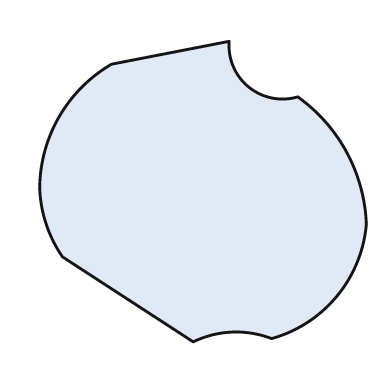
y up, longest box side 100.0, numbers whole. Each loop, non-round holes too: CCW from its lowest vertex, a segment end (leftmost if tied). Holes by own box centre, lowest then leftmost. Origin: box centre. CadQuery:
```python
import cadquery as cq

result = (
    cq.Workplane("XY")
    .moveTo(-3.0, -46.0)
    .threePointArc((9.0, -43.0), (21.0, -45.0))
    .threePointArc((41.0, -32.0), (50.0, -10.0))
    .threePointArc((44.0, 12.0), (29.0, 29.0))
    .threePointArc((14.0, 32.0), (8.0, 46.0))
    .lineTo(-28.0, 39.0)
    .threePointArc((-44.0, 23.0), (-50.0, 1.0))
    .threePointArc((-48.0, -10.0), (-43.0, -20.0))
    .close()
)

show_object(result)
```